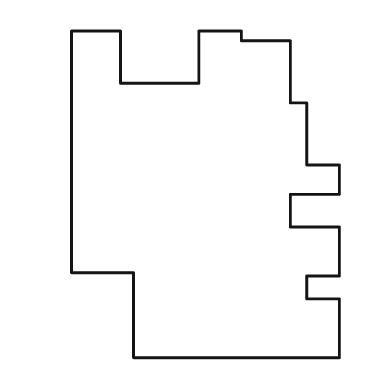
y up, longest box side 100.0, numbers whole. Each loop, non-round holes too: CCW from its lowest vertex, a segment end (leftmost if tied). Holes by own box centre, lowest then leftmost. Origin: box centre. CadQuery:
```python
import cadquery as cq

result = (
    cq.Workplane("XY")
    .moveTo(-22.0, -50.0)
    .lineTo(41.0, -50.0)
    .lineTo(41.0, -32.0)
    .lineTo(31.0, -32.0)
    .lineTo(31.0, -25.0)
    .lineTo(41.0, -25.0)
    .lineTo(41.0, -10.0)
    .lineTo(26.0, -10.0)
    .lineTo(26.0, 0.0)
    .lineTo(41.0, 0.0)
    .lineTo(41.0, 9.0)
    .lineTo(31.0, 9.0)
    .lineTo(31.0, 28.0)
    .lineTo(26.0, 28.0)
    .lineTo(26.0, 47.0)
    .lineTo(11.0, 47.0)
    .lineTo(11.0, 50.0)
    .lineTo(-2.0, 50.0)
    .lineTo(-2.0, 34.0)
    .lineTo(-26.0, 34.0)
    .lineTo(-26.0, 50.0)
    .lineTo(-41.0, 50.0)
    .lineTo(-41.0, -24.0)
    .lineTo(-22.0, -24.0)
    .close()
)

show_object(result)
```